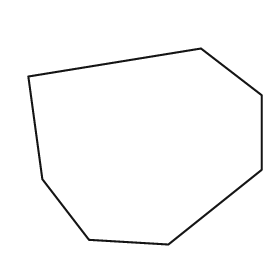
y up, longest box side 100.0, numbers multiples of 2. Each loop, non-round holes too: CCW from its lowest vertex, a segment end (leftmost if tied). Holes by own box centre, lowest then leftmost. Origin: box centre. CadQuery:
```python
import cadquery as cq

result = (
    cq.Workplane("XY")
    .moveTo(10.0, -42.0)
    .lineTo(50.0, -10.0)
    .lineTo(50.0, 22.0)
    .lineTo(24.0, 42.0)
    .lineTo(-50.0, 30.0)
    .lineTo(-44.0, -14.0)
    .lineTo(-24.0, -40.0)
    .close()
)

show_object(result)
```